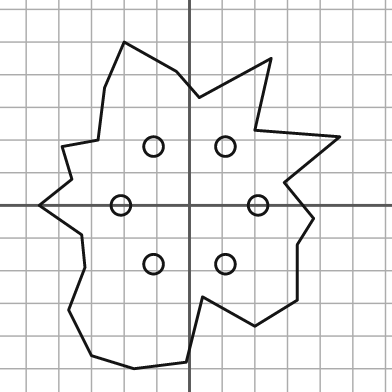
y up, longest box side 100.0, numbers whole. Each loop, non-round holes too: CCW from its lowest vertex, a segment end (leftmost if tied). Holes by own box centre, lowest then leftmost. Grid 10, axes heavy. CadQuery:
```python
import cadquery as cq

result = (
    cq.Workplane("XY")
    .moveTo(-17.0, -50.0)
    .lineTo(-1.0, -48.0)
    .lineTo(4.0, -28.0)
    .lineTo(20.0, -37.0)
    .lineTo(33.0, -29.0)
    .lineTo(33.0, -12.0)
    .lineTo(38.0, -4.0)
    .lineTo(29.0, 7.0)
    .lineTo(46.0, 21.0)
    .lineTo(20.0, 23.0)
    .lineTo(25.0, 45.0)
    .lineTo(3.0, 33.0)
    .lineTo(-4.0, 41.0)
    .lineTo(-20.0, 50.0)
    .lineTo(-26.0, 36.0)
    .lineTo(-28.0, 20.0)
    .lineTo(-39.0, 18.0)
    .lineTo(-36.0, 8.0)
    .lineTo(-46.0, 0.0)
    .lineTo(-33.0, -9.0)
    .lineTo(-32.0, -19.0)
    .lineTo(-37.0, -32.0)
    .lineTo(-30.0, -46.0)
    .close()
    .moveTo(-11.0, -18.0)
    .circle(3.0)
    .moveTo(11.0, -18.0)
    .circle(3.0)
    .moveTo(-21.0, 0.0)
    .circle(3.0)
    .moveTo(21.0, 0.0)
    .circle(3.0)
    .moveTo(-11.0, 18.0)
    .circle(3.0)
    .moveTo(11.0, 18.0)
    .circle(3.0)
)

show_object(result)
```